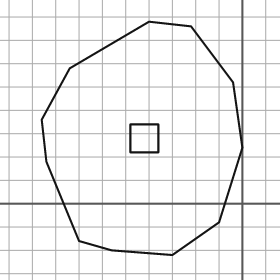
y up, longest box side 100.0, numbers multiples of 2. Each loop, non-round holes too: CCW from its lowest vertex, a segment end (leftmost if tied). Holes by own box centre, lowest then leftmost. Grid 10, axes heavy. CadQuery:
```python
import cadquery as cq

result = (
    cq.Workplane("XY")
    .moveTo(-30.0, -22.0)
    .lineTo(-10.0, -8.0)
    .lineTo(0.0, 24.0)
    .lineTo(-4.0, 52.0)
    .lineTo(-22.0, 76.0)
    .lineTo(-40.0, 78.0)
    .lineTo(-74.0, 58.0)
    .lineTo(-86.0, 36.0)
    .lineTo(-84.0, 18.0)
    .lineTo(-70.0, -16.0)
    .lineTo(-56.0, -20.0)
    .close()
    .moveTo(-48.0, 22.0)
    .lineTo(-36.0, 22.0)
    .lineTo(-36.0, 34.0)
    .lineTo(-48.0, 34.0)
    .close()
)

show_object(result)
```